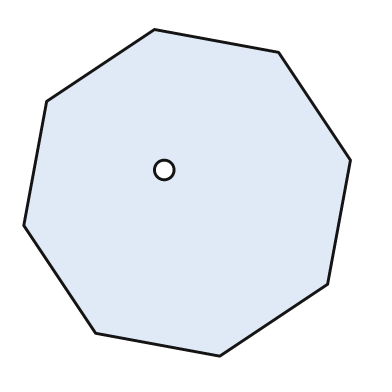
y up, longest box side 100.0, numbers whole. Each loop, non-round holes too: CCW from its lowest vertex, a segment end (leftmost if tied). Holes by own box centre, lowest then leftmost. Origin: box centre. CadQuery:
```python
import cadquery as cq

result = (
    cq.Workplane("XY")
    .moveTo(10.0, -50.0)
    .lineTo(43.0, -28.0)
    .lineTo(50.0, 10.0)
    .lineTo(28.0, 43.0)
    .lineTo(-10.0, 50.0)
    .lineTo(-43.0, 28.0)
    .lineTo(-50.0, -10.0)
    .lineTo(-28.0, -43.0)
    .close()
    .moveTo(-7.0, 7.0)
    .circle(3.0)
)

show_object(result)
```